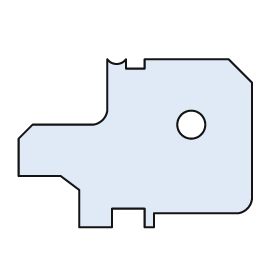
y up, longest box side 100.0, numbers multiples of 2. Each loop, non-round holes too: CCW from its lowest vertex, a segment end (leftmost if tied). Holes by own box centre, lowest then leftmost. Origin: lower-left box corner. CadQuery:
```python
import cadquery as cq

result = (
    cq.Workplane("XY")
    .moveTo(26.0, 0.0)
    .lineTo(40.0, 0.0)
    .lineTo(40.0, 8.0)
    .lineTo(54.0, 8.0)
    .lineTo(54.0, 0.0)
    .lineTo(58.0, 0.0)
    .lineTo(58.0, 6.0)
    .lineTo(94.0, 6.0)
    .threePointArc((98.0, 8.0), (100.0, 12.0))
    .lineTo(100.0, 62.0)
    .lineTo(90.0, 72.0)
    .lineTo(54.0, 72.0)
    .lineTo(54.0, 68.0)
    .lineTo(46.0, 68.0)
    .lineTo(46.0, 72.0)
    .threePointArc((42.0, 70.0), (38.0, 72.0))
    .lineTo(38.0, 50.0)
    .threePointArc((36.0, 46.0), (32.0, 44.0))
    .lineTo(6.0, 44.0)
    .lineTo(0.0, 38.0)
    .lineTo(0.0, 22.0)
    .lineTo(18.0, 22.0)
    .lineTo(26.0, 16.0)
    .close()
    .moveTo(74.0, 44.0)
    .circle(6.0)
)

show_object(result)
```